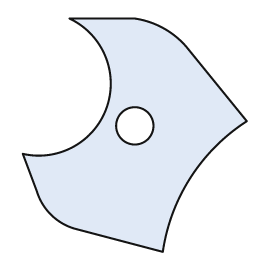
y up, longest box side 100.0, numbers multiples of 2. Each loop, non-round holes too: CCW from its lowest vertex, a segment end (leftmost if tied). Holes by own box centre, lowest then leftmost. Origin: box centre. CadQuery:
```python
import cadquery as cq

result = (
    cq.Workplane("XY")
    .moveTo(12.0, -50.0)
    .threePointArc((24.0, -18.0), (48.0, 6.0))
    .lineTo(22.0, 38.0)
    .threePointArc((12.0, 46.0), (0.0, 50.0))
    .lineTo(-28.0, 50.0)
    .threePointArc((-12.0, 12.0), (-48.0, -8.0))
    .lineTo(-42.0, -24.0)
    .threePointArc((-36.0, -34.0), (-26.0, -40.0))
    .close()
    .moveTo(0.0, 4.0)
    .circle(8.0)
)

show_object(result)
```